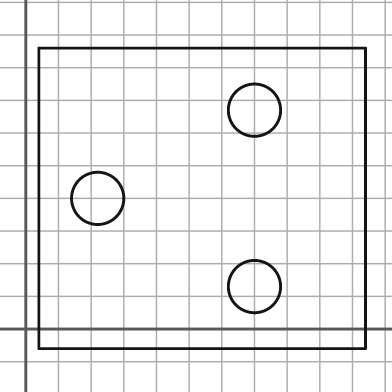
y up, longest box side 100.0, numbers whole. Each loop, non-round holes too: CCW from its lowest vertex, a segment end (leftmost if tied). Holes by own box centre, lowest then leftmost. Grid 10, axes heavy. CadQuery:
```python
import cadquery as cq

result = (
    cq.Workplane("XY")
    .moveTo(4.0, -6.0)
    .lineTo(104.0, -6.0)
    .lineTo(104.0, 86.0)
    .lineTo(4.0, 86.0)
    .close()
    .moveTo(70.0, 13.0)
    .circle(8.0)
    .moveTo(22.0, 40.0)
    .circle(8.0)
    .moveTo(70.0, 67.0)
    .circle(8.0)
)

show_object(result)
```